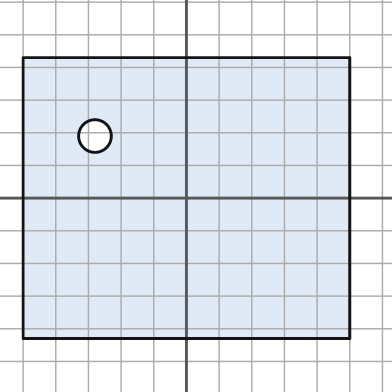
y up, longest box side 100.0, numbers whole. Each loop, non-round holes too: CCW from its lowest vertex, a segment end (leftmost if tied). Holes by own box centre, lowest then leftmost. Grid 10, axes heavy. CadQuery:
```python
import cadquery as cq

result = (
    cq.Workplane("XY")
    .moveTo(-50.0, -43.0)
    .lineTo(50.0, -43.0)
    .lineTo(50.0, 43.0)
    .lineTo(-50.0, 43.0)
    .close()
    .moveTo(-28.0, 19.0)
    .circle(5.0)
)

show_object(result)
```